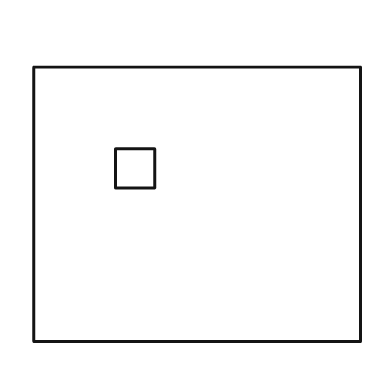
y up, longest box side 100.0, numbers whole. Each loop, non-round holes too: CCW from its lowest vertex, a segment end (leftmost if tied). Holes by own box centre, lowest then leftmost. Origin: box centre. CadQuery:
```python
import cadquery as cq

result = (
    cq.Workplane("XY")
    .moveTo(-50.0, -42.0)
    .lineTo(50.0, -42.0)
    .lineTo(50.0, 42.0)
    .lineTo(-50.0, 42.0)
    .close()
    .moveTo(-25.0, 5.0)
    .lineTo(-13.0, 5.0)
    .lineTo(-13.0, 17.0)
    .lineTo(-25.0, 17.0)
    .close()
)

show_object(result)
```